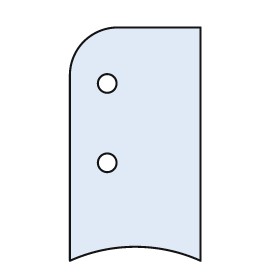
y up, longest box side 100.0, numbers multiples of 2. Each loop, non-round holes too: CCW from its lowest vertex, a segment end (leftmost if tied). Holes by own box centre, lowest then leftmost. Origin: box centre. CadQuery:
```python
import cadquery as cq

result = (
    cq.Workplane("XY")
    .moveTo(-28.0, -50.0)
    .threePointArc((0.0, -44.0), (28.0, -50.0))
    .lineTo(28.0, 50.0)
    .lineTo(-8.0, 50.0)
    .threePointArc((-22.0, 44.0), (-28.0, 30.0))
    .close()
    .moveTo(-12.0, -8.0)
    .circle(4.0)
    .moveTo(-12.0, 26.0)
    .circle(4.0)
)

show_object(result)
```